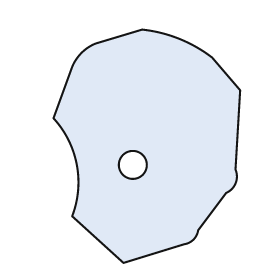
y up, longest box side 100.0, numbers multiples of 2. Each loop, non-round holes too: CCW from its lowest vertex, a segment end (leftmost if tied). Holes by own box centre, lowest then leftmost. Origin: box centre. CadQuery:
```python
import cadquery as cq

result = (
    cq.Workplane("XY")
    .moveTo(-10.0, -50.0)
    .lineTo(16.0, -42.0)
    .threePointArc((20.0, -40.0), (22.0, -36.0))
    .lineTo(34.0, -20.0)
    .threePointArc((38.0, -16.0), (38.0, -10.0))
    .lineTo(40.0, 24.0)
    .lineTo(28.0, 38.0)
    .threePointArc((14.0, 46.0), (-2.0, 50.0))
    .lineTo(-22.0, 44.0)
    .threePointArc((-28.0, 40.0), (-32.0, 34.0))
    .lineTo(-40.0, 12.0)
    .threePointArc((-30.0, -8.0), (-32.0, -30.0))
    .close()
    .moveTo(-6.0, -8.0)
    .circle(6.0)
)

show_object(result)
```